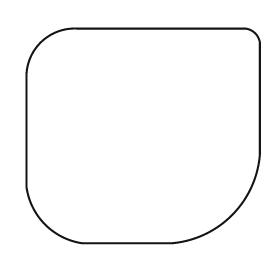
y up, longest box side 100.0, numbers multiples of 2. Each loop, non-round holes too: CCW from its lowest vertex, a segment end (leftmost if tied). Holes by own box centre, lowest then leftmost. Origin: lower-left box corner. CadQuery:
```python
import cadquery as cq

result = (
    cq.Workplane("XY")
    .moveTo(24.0, 0.0)
    .lineTo(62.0, 0.0)
    .threePointArc((88.0, 12.0), (100.0, 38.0))
    .lineTo(100.0, 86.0)
    .threePointArc((98.0, 90.0), (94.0, 92.0))
    .lineTo(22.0, 92.0)
    .threePointArc((6.0, 86.0), (0.0, 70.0))
    .lineTo(0.0, 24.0)
    .threePointArc((8.0, 8.0), (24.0, 0.0))
    .close()
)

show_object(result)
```